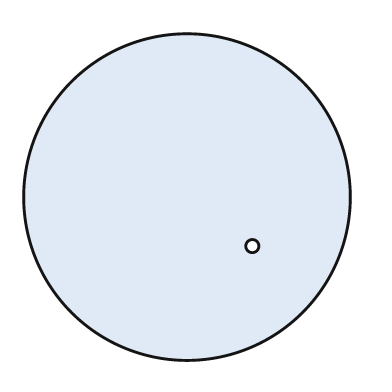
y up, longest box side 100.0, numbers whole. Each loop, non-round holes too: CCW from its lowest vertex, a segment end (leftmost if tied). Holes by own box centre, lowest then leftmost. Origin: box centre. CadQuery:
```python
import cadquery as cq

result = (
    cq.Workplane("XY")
    .moveTo(0.0, 0.0)
    .circle(50.0)
    .moveTo(20.0, -15.0)
    .circle(2.0)
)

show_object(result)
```